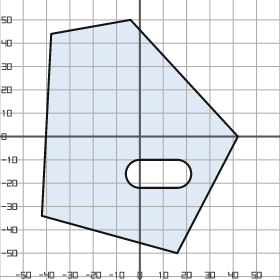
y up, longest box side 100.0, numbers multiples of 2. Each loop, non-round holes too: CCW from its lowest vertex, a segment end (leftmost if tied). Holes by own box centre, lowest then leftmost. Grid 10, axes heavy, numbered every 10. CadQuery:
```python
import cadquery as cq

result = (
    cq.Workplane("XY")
    .moveTo(16.0, -50.0)
    .lineTo(42.0, 0.0)
    .lineTo(-4.0, 50.0)
    .lineTo(-38.0, 44.0)
    .lineTo(-42.0, -34.0)
    .close()
    .moveTo(0.0, -22.0)
    .lineTo(16.0, -22.0)
    .threePointArc((22.0, -16.0), (16.0, -10.0))
    .lineTo(0.0, -10.0)
    .threePointArc((-6.0, -16.0), (0.0, -22.0))
    .close()
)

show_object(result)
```